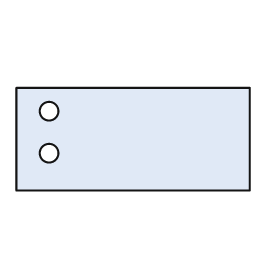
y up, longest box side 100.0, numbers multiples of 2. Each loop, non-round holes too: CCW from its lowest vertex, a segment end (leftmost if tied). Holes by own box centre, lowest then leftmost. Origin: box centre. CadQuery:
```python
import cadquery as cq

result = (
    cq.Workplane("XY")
    .moveTo(-50.0, -22.0)
    .lineTo(50.0, -22.0)
    .lineTo(50.0, 22.0)
    .lineTo(-50.0, 22.0)
    .close()
    .moveTo(-36.0, -6.0)
    .circle(4.0)
    .moveTo(-36.0, 12.0)
    .circle(4.0)
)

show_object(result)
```